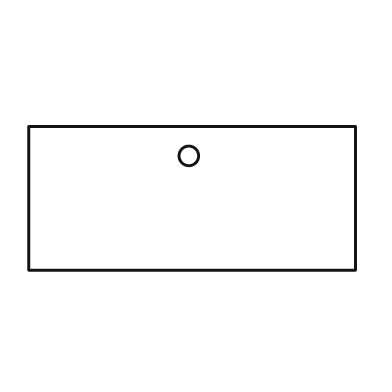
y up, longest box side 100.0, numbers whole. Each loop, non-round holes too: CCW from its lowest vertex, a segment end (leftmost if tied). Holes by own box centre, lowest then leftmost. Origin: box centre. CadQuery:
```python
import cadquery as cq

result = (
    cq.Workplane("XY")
    .moveTo(-50.0, -22.0)
    .lineTo(50.0, -22.0)
    .lineTo(50.0, 22.0)
    .lineTo(-50.0, 22.0)
    .close()
    .moveTo(-1.0, 13.0)
    .circle(3.0)
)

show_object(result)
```